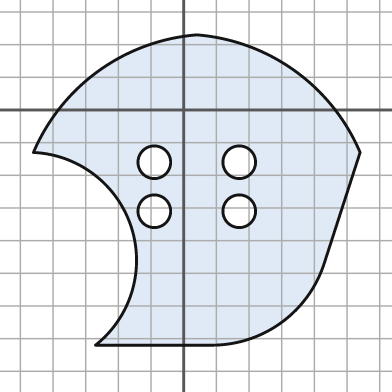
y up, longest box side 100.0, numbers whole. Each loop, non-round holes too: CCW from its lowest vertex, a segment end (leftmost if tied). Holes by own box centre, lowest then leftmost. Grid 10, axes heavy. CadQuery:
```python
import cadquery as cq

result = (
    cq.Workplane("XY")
    .moveTo(-27.0, -72.0)
    .lineTo(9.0, -72.0)
    .threePointArc((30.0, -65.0), (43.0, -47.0))
    .lineTo(54.0, -13.0)
    .threePointArc((34.0, 12.0), (4.0, 23.0))
    .threePointArc((-26.0, 12.0), (-46.0, -13.0))
    .threePointArc((-16.0, -36.0), (-27.0, -72.0))
    .close()
    .moveTo(-9.0, -31.0)
    .circle(5.0)
    .moveTo(17.0, -31.0)
    .circle(5.0)
    .moveTo(-9.0, -16.0)
    .circle(5.0)
    .moveTo(17.0, -16.0)
    .circle(5.0)
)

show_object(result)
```